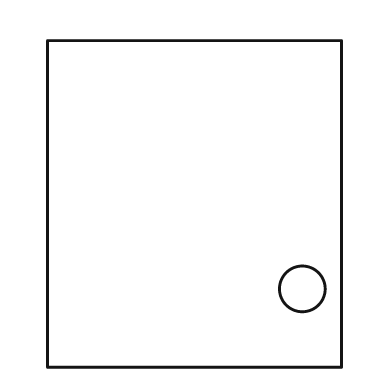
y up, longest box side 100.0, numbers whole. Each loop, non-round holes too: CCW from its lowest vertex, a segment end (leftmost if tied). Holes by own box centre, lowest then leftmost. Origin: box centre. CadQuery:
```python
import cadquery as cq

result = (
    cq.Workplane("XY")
    .moveTo(-45.0, -50.0)
    .lineTo(45.0, -50.0)
    .lineTo(45.0, 50.0)
    .lineTo(-45.0, 50.0)
    .close()
    .moveTo(33.0, -26.0)
    .circle(7.0)
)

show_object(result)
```